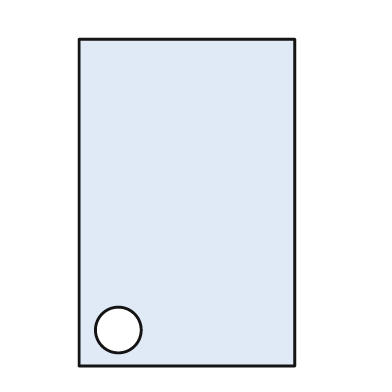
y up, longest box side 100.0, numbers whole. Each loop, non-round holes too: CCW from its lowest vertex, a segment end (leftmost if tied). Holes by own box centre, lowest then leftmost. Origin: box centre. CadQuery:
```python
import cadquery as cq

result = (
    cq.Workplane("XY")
    .moveTo(-33.0, -50.0)
    .lineTo(33.0, -50.0)
    .lineTo(33.0, 50.0)
    .lineTo(-33.0, 50.0)
    .close()
    .moveTo(-21.0, -39.0)
    .circle(7.0)
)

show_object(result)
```